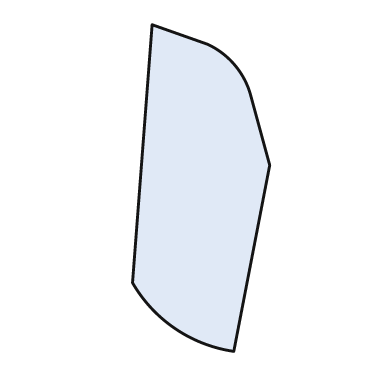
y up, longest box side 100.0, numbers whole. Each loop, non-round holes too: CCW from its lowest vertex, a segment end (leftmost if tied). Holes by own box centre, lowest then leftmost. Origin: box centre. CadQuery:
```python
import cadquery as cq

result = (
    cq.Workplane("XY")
    .moveTo(10.0, -50.0)
    .lineTo(21.0, 7.0)
    .lineTo(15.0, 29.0)
    .threePointArc((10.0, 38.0), (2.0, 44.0))
    .lineTo(-15.0, 50.0)
    .lineTo(-21.0, -29.0)
    .threePointArc((-8.0, -43.0), (10.0, -50.0))
    .close()
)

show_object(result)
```